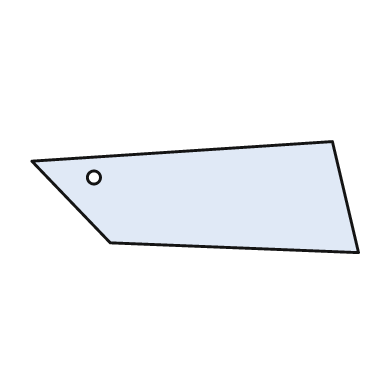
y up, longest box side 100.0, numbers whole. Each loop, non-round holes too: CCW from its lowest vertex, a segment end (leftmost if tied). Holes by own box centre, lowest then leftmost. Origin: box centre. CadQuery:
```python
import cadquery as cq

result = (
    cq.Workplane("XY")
    .moveTo(50.0, -17.0)
    .lineTo(42.0, 17.0)
    .lineTo(-50.0, 11.0)
    .lineTo(-26.0, -14.0)
    .close()
    .moveTo(-31.0, 6.0)
    .circle(2.0)
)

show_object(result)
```